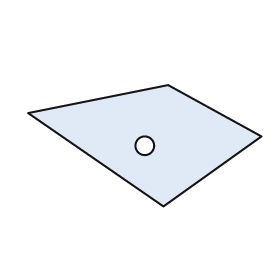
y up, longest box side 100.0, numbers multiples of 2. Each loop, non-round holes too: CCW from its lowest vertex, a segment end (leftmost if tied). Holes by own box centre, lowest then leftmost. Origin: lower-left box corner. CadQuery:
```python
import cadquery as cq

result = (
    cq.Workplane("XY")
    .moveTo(58.0, 0.0)
    .lineTo(100.0, 30.0)
    .lineTo(60.0, 52.0)
    .lineTo(0.0, 40.0)
    .close()
    .moveTo(50.0, 26.0)
    .circle(4.0)
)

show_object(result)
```